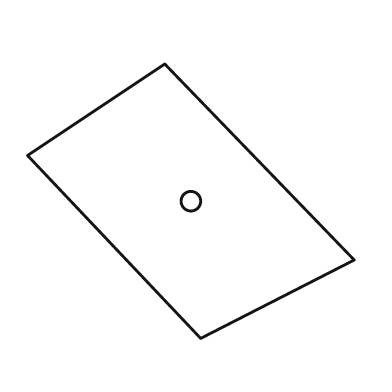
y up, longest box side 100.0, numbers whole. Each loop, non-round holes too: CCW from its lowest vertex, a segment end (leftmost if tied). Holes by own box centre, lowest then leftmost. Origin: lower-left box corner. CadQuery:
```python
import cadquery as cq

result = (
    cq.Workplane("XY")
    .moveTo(53.0, 0.0)
    .lineTo(100.0, 24.0)
    .lineTo(42.0, 84.0)
    .lineTo(0.0, 56.0)
    .close()
    .moveTo(50.0, 42.0)
    .circle(3.0)
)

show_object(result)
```